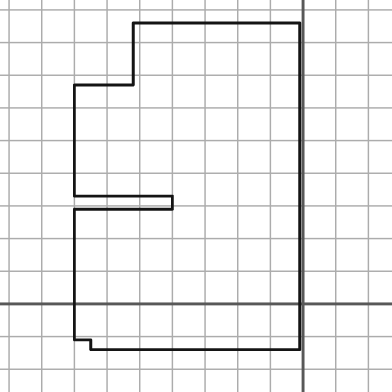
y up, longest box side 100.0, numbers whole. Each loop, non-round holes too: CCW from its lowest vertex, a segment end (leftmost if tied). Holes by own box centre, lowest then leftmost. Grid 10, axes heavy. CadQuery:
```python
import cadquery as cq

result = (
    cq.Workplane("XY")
    .moveTo(-65.0, -14.0)
    .lineTo(-1.0, -14.0)
    .lineTo(-1.0, 86.0)
    .lineTo(-52.0, 86.0)
    .lineTo(-52.0, 67.0)
    .lineTo(-70.0, 67.0)
    .lineTo(-70.0, 33.0)
    .lineTo(-40.0, 33.0)
    .lineTo(-40.0, 29.0)
    .lineTo(-70.0, 29.0)
    .lineTo(-70.0, -11.0)
    .lineTo(-65.0, -11.0)
    .close()
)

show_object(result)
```